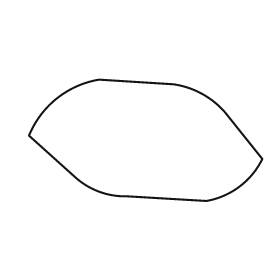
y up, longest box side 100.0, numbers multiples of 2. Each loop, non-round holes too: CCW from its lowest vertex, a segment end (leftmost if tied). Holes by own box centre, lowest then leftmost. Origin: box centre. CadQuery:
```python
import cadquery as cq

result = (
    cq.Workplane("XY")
    .moveTo(26.0, -26.0)
    .threePointArc((40.0, -20.0), (50.0, -8.0))
    .lineTo(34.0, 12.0)
    .threePointArc((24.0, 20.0), (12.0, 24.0))
    .lineTo(-20.0, 26.0)
    .threePointArc((-38.0, 18.0), (-50.0, 2.0))
    .lineTo(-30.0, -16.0)
    .threePointArc((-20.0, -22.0), (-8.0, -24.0))
    .close()
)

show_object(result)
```